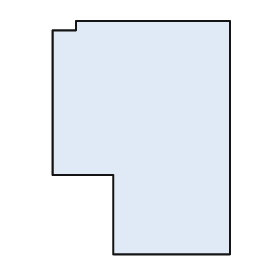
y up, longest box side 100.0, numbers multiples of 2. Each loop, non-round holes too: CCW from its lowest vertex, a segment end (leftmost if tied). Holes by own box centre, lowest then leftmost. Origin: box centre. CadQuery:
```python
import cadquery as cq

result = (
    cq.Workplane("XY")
    .moveTo(-12.0, -50.0)
    .lineTo(38.0, -50.0)
    .lineTo(38.0, 50.0)
    .lineTo(-28.0, 50.0)
    .lineTo(-28.0, 46.0)
    .lineTo(-38.0, 46.0)
    .lineTo(-38.0, -16.0)
    .lineTo(-12.0, -16.0)
    .close()
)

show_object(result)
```